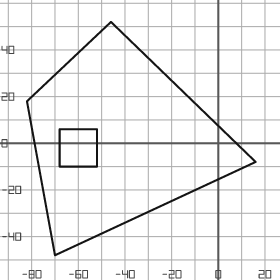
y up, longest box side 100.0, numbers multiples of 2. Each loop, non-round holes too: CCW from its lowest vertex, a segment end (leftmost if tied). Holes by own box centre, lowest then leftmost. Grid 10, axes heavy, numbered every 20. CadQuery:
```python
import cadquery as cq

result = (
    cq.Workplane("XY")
    .moveTo(-70.0, -48.0)
    .lineTo(16.0, -8.0)
    .lineTo(-46.0, 52.0)
    .lineTo(-82.0, 18.0)
    .close()
    .moveTo(-68.0, -10.0)
    .lineTo(-52.0, -10.0)
    .lineTo(-52.0, 6.0)
    .lineTo(-68.0, 6.0)
    .close()
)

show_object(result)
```